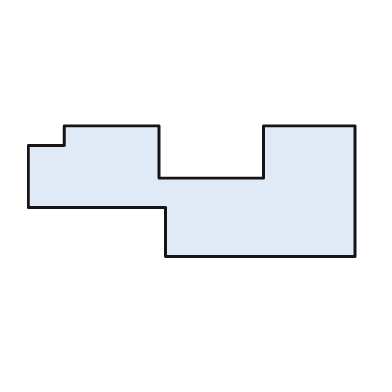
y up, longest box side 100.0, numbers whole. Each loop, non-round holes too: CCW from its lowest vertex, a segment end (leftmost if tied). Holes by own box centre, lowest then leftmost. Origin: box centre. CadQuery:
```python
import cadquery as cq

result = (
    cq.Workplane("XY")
    .moveTo(-8.0, -20.0)
    .lineTo(50.0, -20.0)
    .lineTo(50.0, 20.0)
    .lineTo(22.0, 20.0)
    .lineTo(22.0, 4.0)
    .lineTo(-10.0, 4.0)
    .lineTo(-10.0, 20.0)
    .lineTo(-39.0, 20.0)
    .lineTo(-39.0, 14.0)
    .lineTo(-50.0, 14.0)
    .lineTo(-50.0, -5.0)
    .lineTo(-8.0, -5.0)
    .close()
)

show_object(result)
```